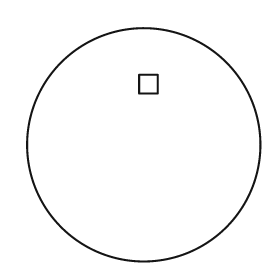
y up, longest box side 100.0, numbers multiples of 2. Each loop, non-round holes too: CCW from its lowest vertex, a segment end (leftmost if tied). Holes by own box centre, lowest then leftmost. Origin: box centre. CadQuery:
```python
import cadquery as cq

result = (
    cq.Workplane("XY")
    .moveTo(0.0, 0.0)
    .circle(50.0)
    .moveTo(-2.0, 22.0)
    .lineTo(6.0, 22.0)
    .lineTo(6.0, 30.0)
    .lineTo(-2.0, 30.0)
    .close()
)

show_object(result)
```